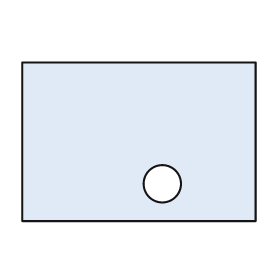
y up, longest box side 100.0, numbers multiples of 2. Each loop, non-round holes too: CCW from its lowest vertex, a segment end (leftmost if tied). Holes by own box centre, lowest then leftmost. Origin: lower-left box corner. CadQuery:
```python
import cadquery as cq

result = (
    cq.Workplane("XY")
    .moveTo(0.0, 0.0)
    .lineTo(100.0, 0.0)
    .lineTo(100.0, 68.0)
    .lineTo(0.0, 68.0)
    .close()
    .moveTo(60.0, 16.0)
    .circle(8.0)
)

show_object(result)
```